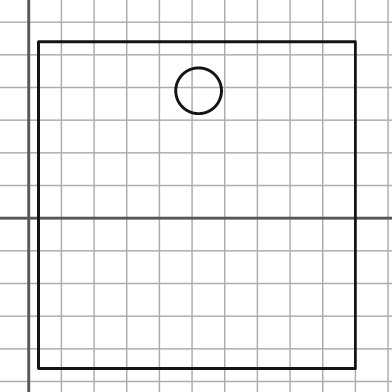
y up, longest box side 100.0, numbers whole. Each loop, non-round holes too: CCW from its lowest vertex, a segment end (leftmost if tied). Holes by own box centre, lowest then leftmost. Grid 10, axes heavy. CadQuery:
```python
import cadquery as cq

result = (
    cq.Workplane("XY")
    .moveTo(3.0, -46.0)
    .lineTo(100.0, -46.0)
    .lineTo(100.0, 54.0)
    .lineTo(3.0, 54.0)
    .close()
    .moveTo(52.0, 39.0)
    .circle(7.0)
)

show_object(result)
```